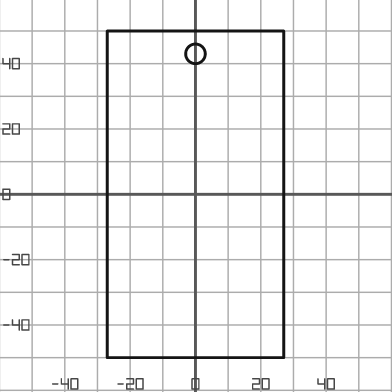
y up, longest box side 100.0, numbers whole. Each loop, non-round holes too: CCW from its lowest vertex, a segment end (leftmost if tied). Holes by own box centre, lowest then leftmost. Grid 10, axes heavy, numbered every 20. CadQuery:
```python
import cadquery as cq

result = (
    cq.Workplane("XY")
    .moveTo(-27.0, -50.0)
    .lineTo(27.0, -50.0)
    .lineTo(27.0, 50.0)
    .lineTo(-27.0, 50.0)
    .close()
    .moveTo(0.0, 43.0)
    .circle(3.0)
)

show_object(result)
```